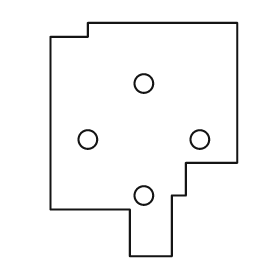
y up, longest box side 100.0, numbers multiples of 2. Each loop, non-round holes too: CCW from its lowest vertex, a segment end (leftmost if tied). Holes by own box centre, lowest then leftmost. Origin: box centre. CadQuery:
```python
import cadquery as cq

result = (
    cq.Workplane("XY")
    .moveTo(-6.0, -50.0)
    .lineTo(12.0, -50.0)
    .lineTo(12.0, -24.0)
    .lineTo(18.0, -24.0)
    .lineTo(18.0, -10.0)
    .lineTo(40.0, -10.0)
    .lineTo(40.0, 50.0)
    .lineTo(-24.0, 50.0)
    .lineTo(-24.0, 44.0)
    .lineTo(-40.0, 44.0)
    .lineTo(-40.0, -30.0)
    .lineTo(-6.0, -30.0)
    .close()
    .moveTo(0.0, -24.0)
    .circle(4.0)
    .moveTo(-24.0, 0.0)
    .circle(4.0)
    .moveTo(24.0, 0.0)
    .circle(4.0)
    .moveTo(0.0, 24.0)
    .circle(4.0)
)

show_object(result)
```